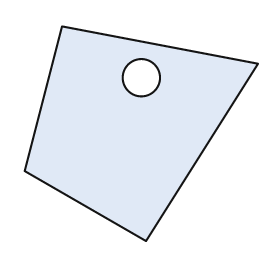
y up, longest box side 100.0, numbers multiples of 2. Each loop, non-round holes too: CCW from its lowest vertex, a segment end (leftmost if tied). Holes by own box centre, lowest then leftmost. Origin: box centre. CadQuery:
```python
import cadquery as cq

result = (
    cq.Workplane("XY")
    .moveTo(2.0, -46.0)
    .lineTo(50.0, 30.0)
    .lineTo(-34.0, 46.0)
    .lineTo(-50.0, -16.0)
    .close()
    .moveTo(0.0, 24.0)
    .circle(8.0)
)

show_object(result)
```